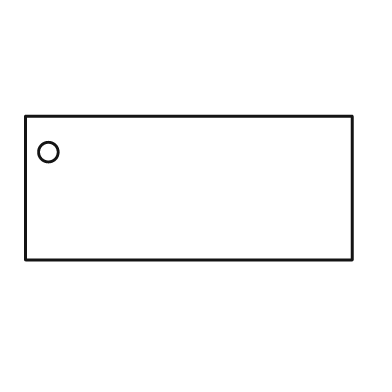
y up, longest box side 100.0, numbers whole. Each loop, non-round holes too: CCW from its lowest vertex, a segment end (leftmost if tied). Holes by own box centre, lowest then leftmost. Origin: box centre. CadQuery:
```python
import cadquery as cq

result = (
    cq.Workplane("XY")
    .moveTo(-50.0, -22.0)
    .lineTo(50.0, -22.0)
    .lineTo(50.0, 22.0)
    .lineTo(-50.0, 22.0)
    .close()
    .moveTo(-43.0, 11.0)
    .circle(3.0)
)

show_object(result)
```